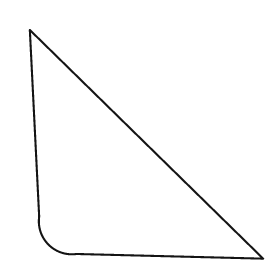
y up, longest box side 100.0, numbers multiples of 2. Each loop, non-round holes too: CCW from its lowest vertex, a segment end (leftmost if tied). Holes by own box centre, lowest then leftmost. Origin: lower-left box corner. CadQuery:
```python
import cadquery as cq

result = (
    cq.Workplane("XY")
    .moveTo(100.0, 0.0)
    .lineTo(0.0, 98.0)
    .lineTo(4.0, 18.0)
    .threePointArc((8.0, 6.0), (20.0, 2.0))
    .close()
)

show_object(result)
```